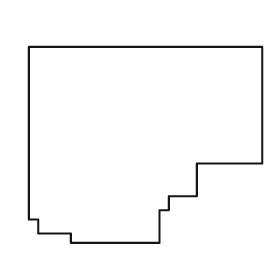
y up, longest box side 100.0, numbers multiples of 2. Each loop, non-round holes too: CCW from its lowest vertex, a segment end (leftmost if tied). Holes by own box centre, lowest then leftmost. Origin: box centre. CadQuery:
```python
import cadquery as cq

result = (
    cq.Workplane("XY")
    .moveTo(-32.0, -42.0)
    .lineTo(6.0, -42.0)
    .lineTo(6.0, -28.0)
    .lineTo(10.0, -28.0)
    .lineTo(10.0, -22.0)
    .lineTo(22.0, -22.0)
    .lineTo(22.0, -8.0)
    .lineTo(50.0, -8.0)
    .lineTo(50.0, 42.0)
    .lineTo(-50.0, 42.0)
    .lineTo(-50.0, -32.0)
    .lineTo(-46.0, -32.0)
    .lineTo(-46.0, -38.0)
    .lineTo(-32.0, -38.0)
    .close()
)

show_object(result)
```